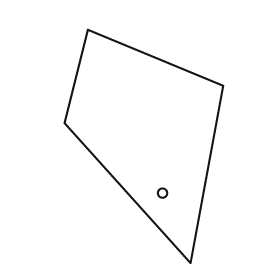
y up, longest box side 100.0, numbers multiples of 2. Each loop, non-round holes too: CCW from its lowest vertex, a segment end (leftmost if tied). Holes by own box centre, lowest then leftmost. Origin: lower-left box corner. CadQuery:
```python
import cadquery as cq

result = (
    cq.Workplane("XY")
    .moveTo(54.0, 0.0)
    .lineTo(68.0, 76.0)
    .lineTo(10.0, 100.0)
    .lineTo(0.0, 60.0)
    .close()
    .moveTo(42.0, 30.0)
    .circle(2.0)
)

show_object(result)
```